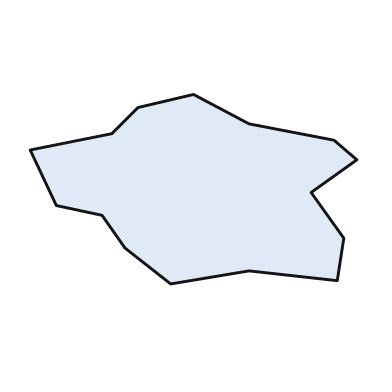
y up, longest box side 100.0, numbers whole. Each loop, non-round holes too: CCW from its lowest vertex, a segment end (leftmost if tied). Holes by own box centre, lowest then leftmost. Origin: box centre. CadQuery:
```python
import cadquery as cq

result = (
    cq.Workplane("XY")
    .moveTo(-7.0, -29.0)
    .lineTo(17.0, -25.0)
    .lineTo(44.0, -28.0)
    .lineTo(46.0, -15.0)
    .lineTo(36.0, -1.0)
    .lineTo(50.0, 9.0)
    .lineTo(43.0, 15.0)
    .lineTo(17.0, 20.0)
    .lineTo(0.0, 29.0)
    .lineTo(-17.0, 25.0)
    .lineTo(-25.0, 17.0)
    .lineTo(-50.0, 12.0)
    .lineTo(-42.0, -5.0)
    .lineTo(-28.0, -8.0)
    .lineTo(-21.0, -18.0)
    .close()
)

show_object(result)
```